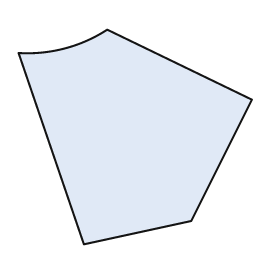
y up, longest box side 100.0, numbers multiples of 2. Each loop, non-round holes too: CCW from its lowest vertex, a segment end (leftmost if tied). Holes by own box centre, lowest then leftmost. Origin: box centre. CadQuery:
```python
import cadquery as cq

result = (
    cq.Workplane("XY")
    .moveTo(-22.0, -46.0)
    .lineTo(24.0, -36.0)
    .lineTo(50.0, 16.0)
    .lineTo(-12.0, 46.0)
    .threePointArc((-30.0, 38.0), (-50.0, 36.0))
    .close()
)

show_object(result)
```